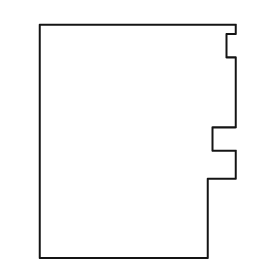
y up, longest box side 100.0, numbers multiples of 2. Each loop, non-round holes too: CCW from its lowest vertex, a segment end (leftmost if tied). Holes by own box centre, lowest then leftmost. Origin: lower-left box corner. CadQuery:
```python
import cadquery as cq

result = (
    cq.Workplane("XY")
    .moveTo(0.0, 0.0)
    .lineTo(72.0, 0.0)
    .lineTo(72.0, 34.0)
    .lineTo(84.0, 34.0)
    .lineTo(84.0, 46.0)
    .lineTo(74.0, 46.0)
    .lineTo(74.0, 56.0)
    .lineTo(84.0, 56.0)
    .lineTo(84.0, 86.0)
    .lineTo(80.0, 86.0)
    .lineTo(80.0, 96.0)
    .lineTo(84.0, 96.0)
    .lineTo(84.0, 100.0)
    .lineTo(0.0, 100.0)
    .close()
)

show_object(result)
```